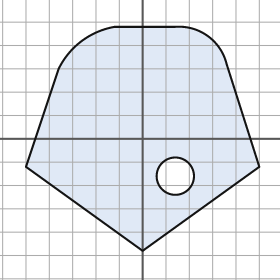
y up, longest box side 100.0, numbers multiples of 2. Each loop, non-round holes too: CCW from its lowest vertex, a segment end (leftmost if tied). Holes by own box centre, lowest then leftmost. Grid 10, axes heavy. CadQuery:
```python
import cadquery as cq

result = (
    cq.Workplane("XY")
    .moveTo(0.0, -48.0)
    .lineTo(50.0, -12.0)
    .lineTo(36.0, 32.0)
    .threePointArc((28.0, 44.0), (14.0, 48.0))
    .lineTo(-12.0, 48.0)
    .threePointArc((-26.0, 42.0), (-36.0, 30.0))
    .lineTo(-50.0, -12.0)
    .close()
    .moveTo(14.0, -16.0)
    .circle(8.0)
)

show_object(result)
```